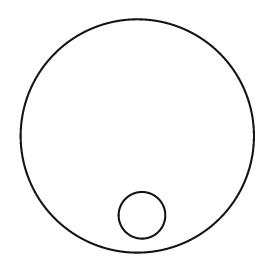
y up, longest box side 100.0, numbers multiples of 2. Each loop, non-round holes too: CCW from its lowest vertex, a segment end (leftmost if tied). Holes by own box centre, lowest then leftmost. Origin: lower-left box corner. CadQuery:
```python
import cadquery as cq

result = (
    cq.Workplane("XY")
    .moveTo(50.0, 50.0)
    .circle(50.0)
    .moveTo(52.0, 16.0)
    .circle(10.0)
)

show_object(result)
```